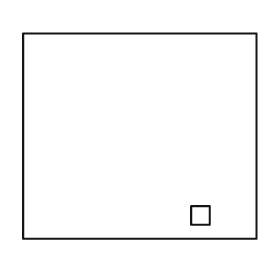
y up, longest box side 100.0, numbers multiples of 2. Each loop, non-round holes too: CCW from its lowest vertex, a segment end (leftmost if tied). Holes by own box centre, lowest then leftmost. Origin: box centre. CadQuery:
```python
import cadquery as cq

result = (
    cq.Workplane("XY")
    .moveTo(-50.0, -44.0)
    .lineTo(50.0, -44.0)
    .lineTo(50.0, 44.0)
    .lineTo(-50.0, 44.0)
    .close()
    .moveTo(22.0, -38.0)
    .lineTo(30.0, -38.0)
    .lineTo(30.0, -30.0)
    .lineTo(22.0, -30.0)
    .close()
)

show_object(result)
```